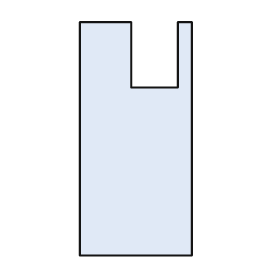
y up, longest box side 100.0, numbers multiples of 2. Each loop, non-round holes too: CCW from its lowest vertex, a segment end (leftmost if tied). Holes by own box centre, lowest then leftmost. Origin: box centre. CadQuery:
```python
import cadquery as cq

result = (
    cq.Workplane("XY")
    .moveTo(-24.0, -50.0)
    .lineTo(24.0, -50.0)
    .lineTo(24.0, 50.0)
    .lineTo(18.0, 50.0)
    .lineTo(18.0, 22.0)
    .lineTo(-2.0, 22.0)
    .lineTo(-2.0, 50.0)
    .lineTo(-24.0, 50.0)
    .close()
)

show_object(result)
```